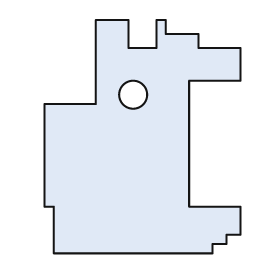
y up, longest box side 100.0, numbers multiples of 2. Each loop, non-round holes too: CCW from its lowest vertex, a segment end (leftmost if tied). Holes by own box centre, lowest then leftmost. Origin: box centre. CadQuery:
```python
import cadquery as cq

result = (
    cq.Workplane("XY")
    .moveTo(-38.0, -50.0)
    .lineTo(30.0, -50.0)
    .lineTo(30.0, -46.0)
    .lineTo(36.0, -46.0)
    .lineTo(36.0, -42.0)
    .lineTo(42.0, -42.0)
    .lineTo(42.0, -30.0)
    .lineTo(20.0, -30.0)
    .lineTo(20.0, 24.0)
    .lineTo(42.0, 24.0)
    .lineTo(42.0, 38.0)
    .lineTo(24.0, 38.0)
    .lineTo(24.0, 44.0)
    .lineTo(10.0, 44.0)
    .lineTo(10.0, 50.0)
    .lineTo(6.0, 50.0)
    .lineTo(6.0, 38.0)
    .lineTo(-6.0, 38.0)
    .lineTo(-6.0, 50.0)
    .lineTo(-20.0, 50.0)
    .lineTo(-20.0, 14.0)
    .lineTo(-42.0, 14.0)
    .lineTo(-42.0, -30.0)
    .lineTo(-38.0, -30.0)
    .close()
    .moveTo(-4.0, 18.0)
    .circle(6.0)
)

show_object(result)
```